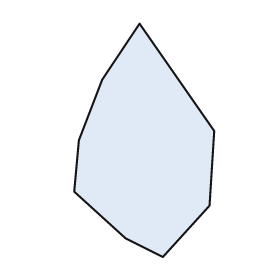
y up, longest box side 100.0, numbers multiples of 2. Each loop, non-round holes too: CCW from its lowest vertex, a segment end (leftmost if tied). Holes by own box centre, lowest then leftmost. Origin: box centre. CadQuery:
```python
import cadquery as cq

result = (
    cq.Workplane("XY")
    .moveTo(8.0, -50.0)
    .lineTo(28.0, -28.0)
    .lineTo(30.0, 4.0)
    .lineTo(-2.0, 50.0)
    .lineTo(-18.0, 26.0)
    .lineTo(-28.0, 0.0)
    .lineTo(-30.0, -22.0)
    .lineTo(-8.0, -42.0)
    .close()
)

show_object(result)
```